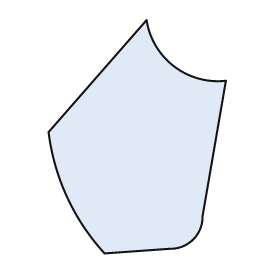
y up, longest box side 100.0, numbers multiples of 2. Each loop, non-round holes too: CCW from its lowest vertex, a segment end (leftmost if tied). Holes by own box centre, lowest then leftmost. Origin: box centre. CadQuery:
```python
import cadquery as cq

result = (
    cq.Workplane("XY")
    .moveTo(-14.0, -50.0)
    .lineTo(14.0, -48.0)
    .threePointArc((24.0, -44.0), (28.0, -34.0))
    .lineTo(38.0, 24.0)
    .threePointArc((16.0, 30.0), (4.0, 50.0))
    .lineTo(-38.0, 2.0)
    .threePointArc((-30.0, -26.0), (-14.0, -50.0))
    .close()
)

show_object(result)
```